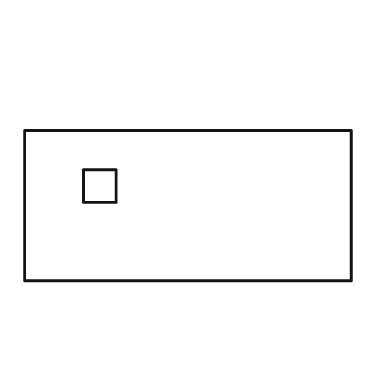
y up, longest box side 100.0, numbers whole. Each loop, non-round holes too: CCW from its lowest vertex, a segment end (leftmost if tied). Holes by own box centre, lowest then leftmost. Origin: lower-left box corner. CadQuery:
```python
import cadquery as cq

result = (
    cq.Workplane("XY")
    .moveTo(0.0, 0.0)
    .lineTo(100.0, 0.0)
    .lineTo(100.0, 46.0)
    .lineTo(0.0, 46.0)
    .close()
    .moveTo(18.0, 24.0)
    .lineTo(28.0, 24.0)
    .lineTo(28.0, 34.0)
    .lineTo(18.0, 34.0)
    .close()
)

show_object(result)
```